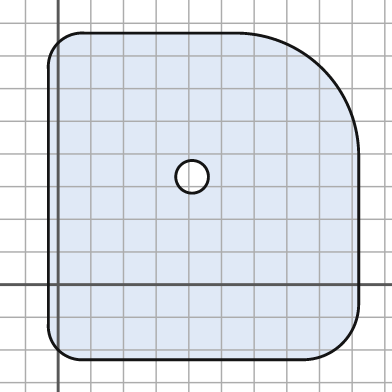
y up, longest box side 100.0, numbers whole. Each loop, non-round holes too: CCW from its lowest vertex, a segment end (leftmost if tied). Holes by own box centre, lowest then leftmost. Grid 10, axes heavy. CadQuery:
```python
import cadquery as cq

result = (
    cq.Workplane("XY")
    .moveTo(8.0, -23.0)
    .lineTo(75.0, -23.0)
    .threePointArc((87.0, -18.0), (92.0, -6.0))
    .lineTo(92.0, 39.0)
    .threePointArc((81.0, 66.0), (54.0, 77.0))
    .lineTo(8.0, 77.0)
    .threePointArc((0.0, 74.0), (-3.0, 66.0))
    .lineTo(-3.0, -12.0)
    .threePointArc((0.0, -20.0), (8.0, -23.0))
    .close()
    .moveTo(41.0, 33.0)
    .circle(5.0)
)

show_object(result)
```